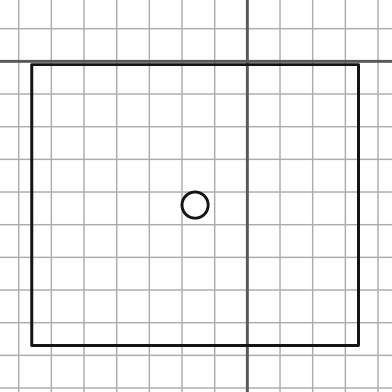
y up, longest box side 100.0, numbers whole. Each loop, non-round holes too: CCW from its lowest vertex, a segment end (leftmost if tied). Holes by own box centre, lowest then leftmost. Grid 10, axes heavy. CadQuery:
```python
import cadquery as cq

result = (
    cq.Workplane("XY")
    .moveTo(-66.0, -87.0)
    .lineTo(34.0, -87.0)
    .lineTo(34.0, -1.0)
    .lineTo(-66.0, -1.0)
    .close()
    .moveTo(-16.0, -44.0)
    .circle(4.0)
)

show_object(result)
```